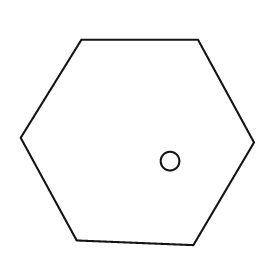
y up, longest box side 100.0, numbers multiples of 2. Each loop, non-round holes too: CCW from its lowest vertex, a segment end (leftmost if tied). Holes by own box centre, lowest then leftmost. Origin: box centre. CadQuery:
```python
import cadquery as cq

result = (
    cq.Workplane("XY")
    .moveTo(24.0, -44.0)
    .lineTo(50.0, 0.0)
    .lineTo(26.0, 44.0)
    .lineTo(-24.0, 44.0)
    .lineTo(-50.0, 2.0)
    .lineTo(-26.0, -42.0)
    .close()
    .moveTo(14.0, -8.0)
    .circle(4.0)
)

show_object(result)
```